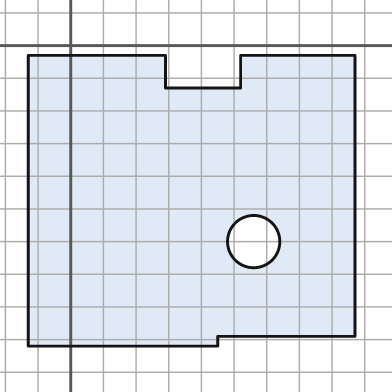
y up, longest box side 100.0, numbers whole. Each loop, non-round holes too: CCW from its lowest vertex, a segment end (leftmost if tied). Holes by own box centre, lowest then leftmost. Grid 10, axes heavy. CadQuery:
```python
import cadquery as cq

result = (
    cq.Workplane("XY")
    .moveTo(-13.0, -92.0)
    .lineTo(45.0, -92.0)
    .lineTo(45.0, -89.0)
    .lineTo(87.0, -89.0)
    .lineTo(87.0, -3.0)
    .lineTo(52.0, -3.0)
    .lineTo(52.0, -13.0)
    .lineTo(29.0, -13.0)
    .lineTo(29.0, -3.0)
    .lineTo(-13.0, -3.0)
    .close()
    .moveTo(56.0, -60.0)
    .circle(8.0)
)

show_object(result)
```